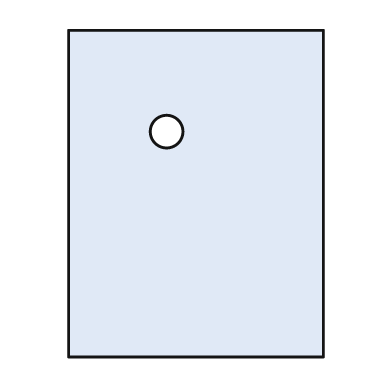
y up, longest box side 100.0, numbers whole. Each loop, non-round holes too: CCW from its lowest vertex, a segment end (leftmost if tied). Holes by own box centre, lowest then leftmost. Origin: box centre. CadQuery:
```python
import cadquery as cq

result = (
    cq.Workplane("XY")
    .moveTo(-39.0, -50.0)
    .lineTo(39.0, -50.0)
    .lineTo(39.0, 50.0)
    .lineTo(-39.0, 50.0)
    .close()
    .moveTo(-9.0, 19.0)
    .circle(5.0)
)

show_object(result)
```